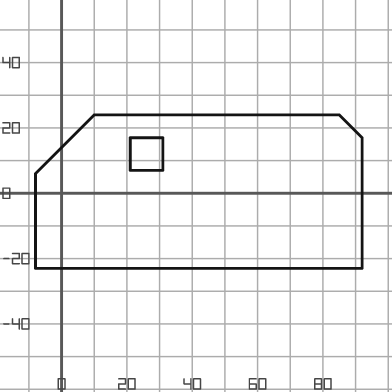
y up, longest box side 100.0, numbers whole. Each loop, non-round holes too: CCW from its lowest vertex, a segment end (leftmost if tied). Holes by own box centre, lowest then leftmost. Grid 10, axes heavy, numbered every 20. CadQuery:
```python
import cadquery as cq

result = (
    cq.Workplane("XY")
    .moveTo(-8.0, -23.0)
    .lineTo(92.0, -23.0)
    .lineTo(92.0, 17.0)
    .lineTo(85.0, 24.0)
    .lineTo(10.0, 24.0)
    .lineTo(-8.0, 6.0)
    .close()
    .moveTo(21.0, 7.0)
    .lineTo(31.0, 7.0)
    .lineTo(31.0, 17.0)
    .lineTo(21.0, 17.0)
    .close()
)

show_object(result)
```